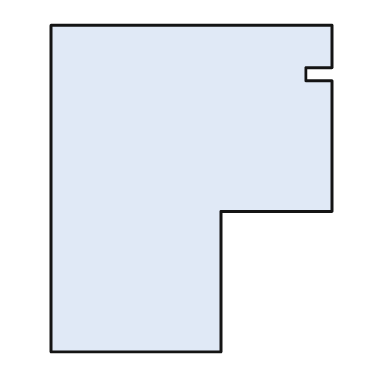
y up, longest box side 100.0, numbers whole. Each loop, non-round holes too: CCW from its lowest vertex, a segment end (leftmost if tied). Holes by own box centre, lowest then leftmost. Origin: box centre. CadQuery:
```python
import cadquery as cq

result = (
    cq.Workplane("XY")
    .moveTo(-43.0, -50.0)
    .lineTo(9.0, -50.0)
    .lineTo(9.0, -7.0)
    .lineTo(43.0, -7.0)
    .lineTo(43.0, 33.0)
    .lineTo(35.0, 33.0)
    .lineTo(35.0, 37.0)
    .lineTo(43.0, 37.0)
    .lineTo(43.0, 50.0)
    .lineTo(-43.0, 50.0)
    .close()
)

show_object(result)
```